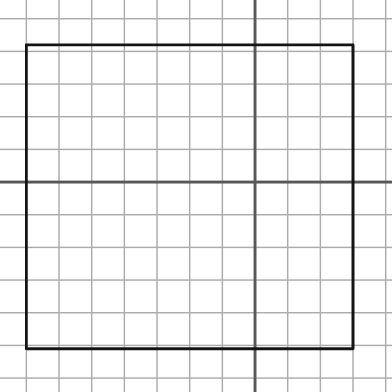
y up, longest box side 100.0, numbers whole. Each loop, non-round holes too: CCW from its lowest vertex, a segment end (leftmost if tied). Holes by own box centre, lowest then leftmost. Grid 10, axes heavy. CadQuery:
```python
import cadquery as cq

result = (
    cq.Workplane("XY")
    .moveTo(-70.0, -51.0)
    .lineTo(30.0, -51.0)
    .lineTo(30.0, 42.0)
    .lineTo(-70.0, 42.0)
    .close()
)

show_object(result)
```